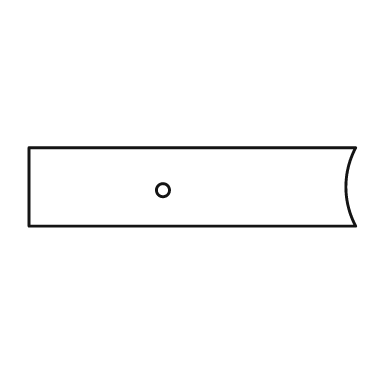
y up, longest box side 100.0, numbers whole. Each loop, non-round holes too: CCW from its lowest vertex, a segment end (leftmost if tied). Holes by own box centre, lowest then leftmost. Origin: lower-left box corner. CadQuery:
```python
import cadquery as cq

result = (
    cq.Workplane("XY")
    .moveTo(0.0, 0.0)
    .lineTo(100.0, 0.0)
    .threePointArc((97.0, 12.0), (100.0, 24.0))
    .lineTo(0.0, 24.0)
    .close()
    .moveTo(41.0, 11.0)
    .circle(2.0)
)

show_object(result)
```